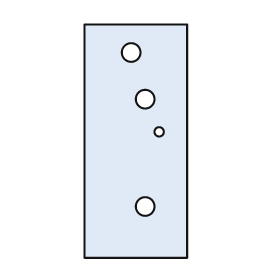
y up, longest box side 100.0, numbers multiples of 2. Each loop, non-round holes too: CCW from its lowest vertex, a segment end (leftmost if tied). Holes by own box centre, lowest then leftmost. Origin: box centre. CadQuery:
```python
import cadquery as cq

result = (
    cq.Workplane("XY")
    .moveTo(-22.0, -50.0)
    .lineTo(22.0, -50.0)
    .lineTo(22.0, 50.0)
    .lineTo(-22.0, 50.0)
    .close()
    .moveTo(4.0, -28.0)
    .circle(4.0)
    .moveTo(10.0, 4.0)
    .circle(2.0)
    .moveTo(4.0, 18.0)
    .circle(4.0)
    .moveTo(-2.0, 38.0)
    .circle(4.0)
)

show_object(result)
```